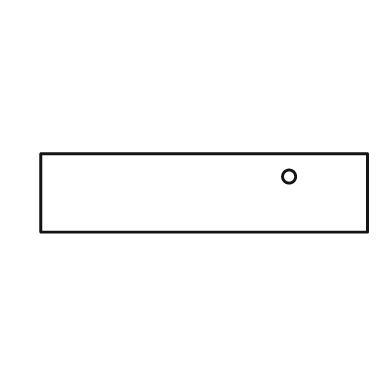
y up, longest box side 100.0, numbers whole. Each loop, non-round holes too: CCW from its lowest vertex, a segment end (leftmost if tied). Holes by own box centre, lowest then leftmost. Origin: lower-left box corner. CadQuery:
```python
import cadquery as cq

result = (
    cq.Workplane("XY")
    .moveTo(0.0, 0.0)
    .lineTo(100.0, 0.0)
    .lineTo(100.0, 24.0)
    .lineTo(0.0, 24.0)
    .close()
    .moveTo(76.0, 17.0)
    .circle(2.0)
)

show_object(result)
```